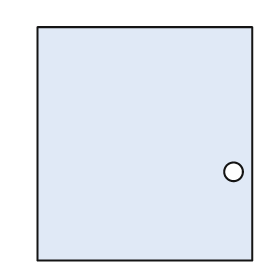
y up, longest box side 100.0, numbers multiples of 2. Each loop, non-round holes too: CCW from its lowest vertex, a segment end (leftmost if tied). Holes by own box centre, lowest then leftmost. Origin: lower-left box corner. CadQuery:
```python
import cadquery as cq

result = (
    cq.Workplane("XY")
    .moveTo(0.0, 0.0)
    .lineTo(92.0, 0.0)
    .lineTo(92.0, 100.0)
    .lineTo(0.0, 100.0)
    .close()
    .moveTo(84.0, 38.0)
    .circle(4.0)
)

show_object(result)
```